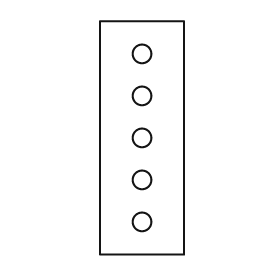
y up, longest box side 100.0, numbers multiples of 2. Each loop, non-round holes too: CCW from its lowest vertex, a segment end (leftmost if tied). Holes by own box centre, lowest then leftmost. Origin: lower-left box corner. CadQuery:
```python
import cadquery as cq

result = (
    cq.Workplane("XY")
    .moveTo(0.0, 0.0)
    .lineTo(36.0, 0.0)
    .lineTo(36.0, 100.0)
    .lineTo(0.0, 100.0)
    .close()
    .moveTo(18.0, 14.0)
    .circle(4.0)
    .moveTo(18.0, 32.0)
    .circle(4.0)
    .moveTo(18.0, 50.0)
    .circle(4.0)
    .moveTo(18.0, 68.0)
    .circle(4.0)
    .moveTo(18.0, 86.0)
    .circle(4.0)
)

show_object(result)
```